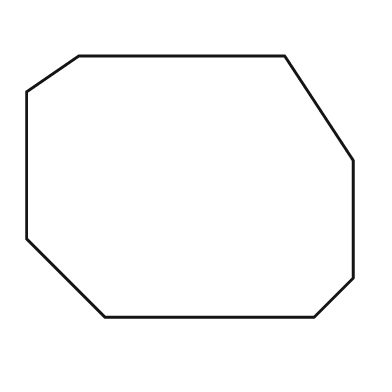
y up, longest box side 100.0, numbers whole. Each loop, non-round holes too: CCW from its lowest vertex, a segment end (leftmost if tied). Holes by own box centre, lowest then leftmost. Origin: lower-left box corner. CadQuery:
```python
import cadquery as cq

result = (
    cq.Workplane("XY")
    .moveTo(24.0, 0.0)
    .lineTo(88.0, 0.0)
    .lineTo(100.0, 12.0)
    .lineTo(100.0, 48.0)
    .lineTo(79.0, 80.0)
    .lineTo(16.0, 80.0)
    .lineTo(0.0, 69.0)
    .lineTo(0.0, 24.0)
    .close()
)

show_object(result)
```